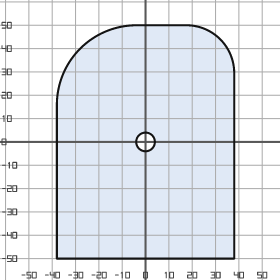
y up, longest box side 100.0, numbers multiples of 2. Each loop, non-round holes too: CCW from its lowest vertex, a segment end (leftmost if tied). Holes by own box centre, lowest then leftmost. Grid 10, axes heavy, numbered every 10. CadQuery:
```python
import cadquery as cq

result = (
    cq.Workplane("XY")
    .moveTo(-38.0, -50.0)
    .lineTo(38.0, -50.0)
    .lineTo(38.0, 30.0)
    .threePointArc((32.0, 44.0), (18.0, 50.0))
    .lineTo(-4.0, 50.0)
    .threePointArc((-28.0, 40.0), (-38.0, 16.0))
    .close()
    .moveTo(0.0, 0.0)
    .circle(4.0)
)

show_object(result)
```